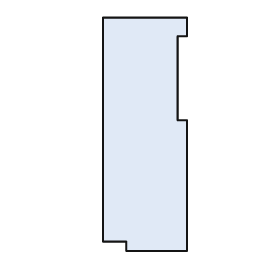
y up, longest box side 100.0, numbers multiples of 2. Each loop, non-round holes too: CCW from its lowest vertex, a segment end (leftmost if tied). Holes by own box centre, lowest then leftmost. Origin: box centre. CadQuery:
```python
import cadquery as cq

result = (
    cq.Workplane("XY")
    .moveTo(-8.0, -50.0)
    .lineTo(18.0, -50.0)
    .lineTo(18.0, 6.0)
    .lineTo(14.0, 6.0)
    .lineTo(14.0, 42.0)
    .lineTo(18.0, 42.0)
    .lineTo(18.0, 50.0)
    .lineTo(-18.0, 50.0)
    .lineTo(-18.0, -46.0)
    .lineTo(-8.0, -46.0)
    .close()
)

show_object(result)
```